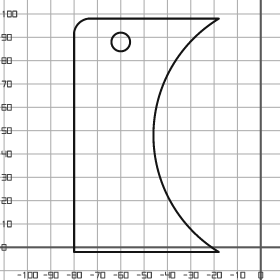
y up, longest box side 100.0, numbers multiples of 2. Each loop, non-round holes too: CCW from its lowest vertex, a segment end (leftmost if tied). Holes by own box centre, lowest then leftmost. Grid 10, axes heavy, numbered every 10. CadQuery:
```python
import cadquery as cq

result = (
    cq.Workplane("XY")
    .moveTo(-80.0, -2.0)
    .lineTo(-18.0, -2.0)
    .threePointArc((-46.0, 48.0), (-18.0, 98.0))
    .lineTo(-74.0, 98.0)
    .threePointArc((-78.0, 96.0), (-80.0, 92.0))
    .close()
    .moveTo(-60.0, 88.0)
    .circle(4.0)
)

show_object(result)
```